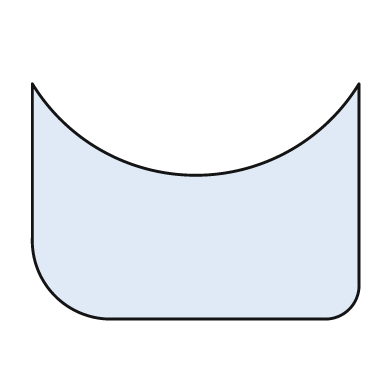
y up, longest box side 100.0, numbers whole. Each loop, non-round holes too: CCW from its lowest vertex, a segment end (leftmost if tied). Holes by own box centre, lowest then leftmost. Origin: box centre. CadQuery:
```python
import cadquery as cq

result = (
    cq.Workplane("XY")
    .moveTo(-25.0, -36.0)
    .lineTo(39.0, -36.0)
    .threePointArc((47.0, -33.0), (50.0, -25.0))
    .lineTo(50.0, 36.0)
    .threePointArc((0.0, 8.0), (-50.0, 36.0))
    .lineTo(-50.0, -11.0)
    .threePointArc((-43.0, -29.0), (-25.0, -36.0))
    .close()
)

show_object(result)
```